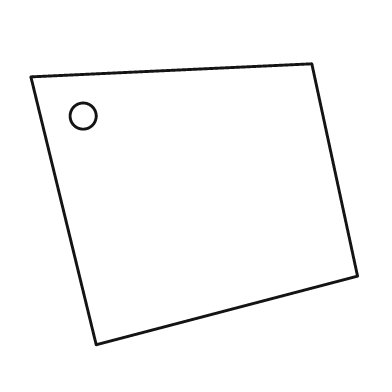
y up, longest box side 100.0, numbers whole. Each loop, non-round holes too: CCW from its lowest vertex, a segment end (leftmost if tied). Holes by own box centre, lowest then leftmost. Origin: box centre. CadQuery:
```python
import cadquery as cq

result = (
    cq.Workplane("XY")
    .moveTo(-30.0, -43.0)
    .lineTo(50.0, -22.0)
    .lineTo(36.0, 43.0)
    .lineTo(-50.0, 39.0)
    .close()
    .moveTo(-34.0, 27.0)
    .circle(4.0)
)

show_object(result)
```